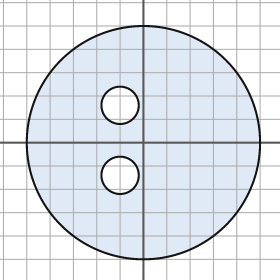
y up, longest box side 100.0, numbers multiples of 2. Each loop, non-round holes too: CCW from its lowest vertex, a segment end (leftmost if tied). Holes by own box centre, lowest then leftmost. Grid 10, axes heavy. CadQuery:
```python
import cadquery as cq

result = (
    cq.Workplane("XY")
    .moveTo(0.0, 0.0)
    .circle(50.0)
    .moveTo(-10.0, -14.0)
    .circle(8.0)
    .moveTo(-10.0, 16.0)
    .circle(8.0)
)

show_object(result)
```